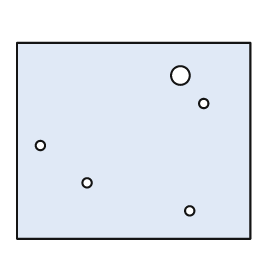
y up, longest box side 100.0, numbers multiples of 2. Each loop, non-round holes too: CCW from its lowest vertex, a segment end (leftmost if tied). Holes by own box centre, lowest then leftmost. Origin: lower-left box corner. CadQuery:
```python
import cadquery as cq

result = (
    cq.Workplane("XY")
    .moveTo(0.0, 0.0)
    .lineTo(100.0, 0.0)
    .lineTo(100.0, 84.0)
    .lineTo(0.0, 84.0)
    .close()
    .moveTo(74.0, 12.0)
    .circle(2.0)
    .moveTo(30.0, 24.0)
    .circle(2.0)
    .moveTo(10.0, 40.0)
    .circle(2.0)
    .moveTo(80.0, 58.0)
    .circle(2.0)
    .moveTo(70.0, 70.0)
    .circle(4.0)
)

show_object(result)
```